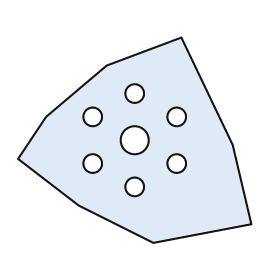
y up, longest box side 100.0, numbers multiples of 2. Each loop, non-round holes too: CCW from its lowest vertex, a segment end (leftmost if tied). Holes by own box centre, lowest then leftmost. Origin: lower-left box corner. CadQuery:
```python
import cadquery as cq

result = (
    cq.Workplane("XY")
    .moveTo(58.0, 0.0)
    .lineTo(100.0, 8.0)
    .lineTo(92.0, 42.0)
    .lineTo(70.0, 88.0)
    .lineTo(38.0, 76.0)
    .lineTo(12.0, 54.0)
    .lineTo(0.0, 36.0)
    .lineTo(26.0, 16.0)
    .close()
    .moveTo(50.0, 24.0)
    .circle(4.0)
    .moveTo(32.0, 34.0)
    .circle(4.0)
    .moveTo(68.0, 34.0)
    .circle(4.0)
    .moveTo(50.0, 44.0)
    .circle(6.0)
    .moveTo(32.0, 54.0)
    .circle(4.0)
    .moveTo(68.0, 54.0)
    .circle(4.0)
    .moveTo(50.0, 64.0)
    .circle(4.0)
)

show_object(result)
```